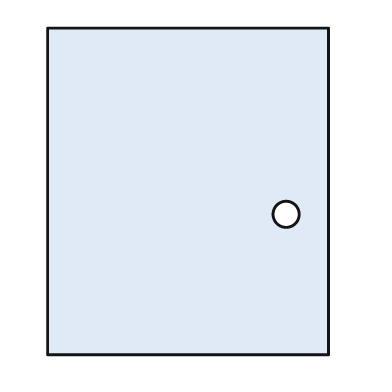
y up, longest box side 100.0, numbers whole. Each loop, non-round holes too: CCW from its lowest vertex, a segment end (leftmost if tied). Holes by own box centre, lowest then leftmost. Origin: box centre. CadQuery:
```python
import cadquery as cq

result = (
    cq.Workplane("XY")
    .moveTo(-43.0, -50.0)
    .lineTo(43.0, -50.0)
    .lineTo(43.0, 50.0)
    .lineTo(-43.0, 50.0)
    .close()
    .moveTo(30.0, -7.0)
    .circle(4.0)
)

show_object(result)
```